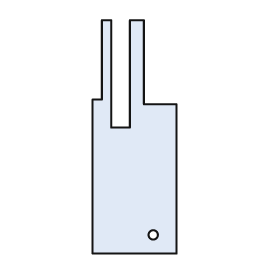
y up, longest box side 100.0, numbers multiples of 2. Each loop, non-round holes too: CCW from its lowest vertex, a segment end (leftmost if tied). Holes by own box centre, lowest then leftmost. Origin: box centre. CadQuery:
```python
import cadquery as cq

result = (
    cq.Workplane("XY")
    .moveTo(-18.0, -50.0)
    .lineTo(18.0, -50.0)
    .lineTo(18.0, 14.0)
    .lineTo(4.0, 14.0)
    .lineTo(4.0, 50.0)
    .lineTo(-2.0, 50.0)
    .lineTo(-2.0, 4.0)
    .lineTo(-10.0, 4.0)
    .lineTo(-10.0, 50.0)
    .lineTo(-14.0, 50.0)
    .lineTo(-14.0, 16.0)
    .lineTo(-18.0, 16.0)
    .close()
    .moveTo(8.0, -42.0)
    .circle(2.0)
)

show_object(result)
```